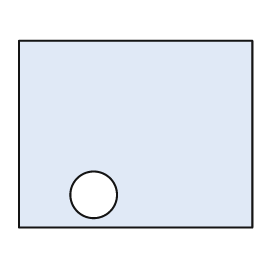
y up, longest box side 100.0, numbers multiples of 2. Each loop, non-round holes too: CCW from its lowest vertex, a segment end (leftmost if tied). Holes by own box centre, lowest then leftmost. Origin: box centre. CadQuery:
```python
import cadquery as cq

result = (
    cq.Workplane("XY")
    .moveTo(-50.0, -40.0)
    .lineTo(50.0, -40.0)
    .lineTo(50.0, 40.0)
    .lineTo(-50.0, 40.0)
    .close()
    .moveTo(-18.0, -26.0)
    .circle(10.0)
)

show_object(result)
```